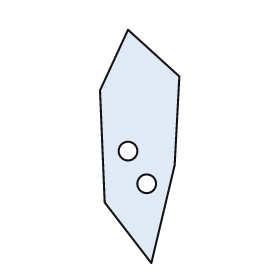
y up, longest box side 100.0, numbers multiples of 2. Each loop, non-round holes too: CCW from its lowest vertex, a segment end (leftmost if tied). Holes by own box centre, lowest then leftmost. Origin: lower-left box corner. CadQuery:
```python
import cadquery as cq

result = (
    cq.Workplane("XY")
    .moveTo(22.0, 0.0)
    .lineTo(32.0, 42.0)
    .lineTo(34.0, 80.0)
    .lineTo(12.0, 100.0)
    .lineTo(0.0, 74.0)
    .lineTo(2.0, 26.0)
    .close()
    .moveTo(20.0, 34.0)
    .circle(4.0)
    .moveTo(12.0, 48.0)
    .circle(4.0)
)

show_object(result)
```